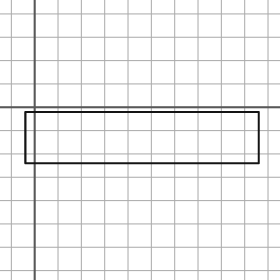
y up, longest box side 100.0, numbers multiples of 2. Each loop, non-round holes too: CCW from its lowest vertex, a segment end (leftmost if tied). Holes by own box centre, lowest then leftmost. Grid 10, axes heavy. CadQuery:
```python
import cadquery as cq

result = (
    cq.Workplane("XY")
    .moveTo(-4.0, -24.0)
    .lineTo(96.0, -24.0)
    .lineTo(96.0, -2.0)
    .lineTo(-4.0, -2.0)
    .close()
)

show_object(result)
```